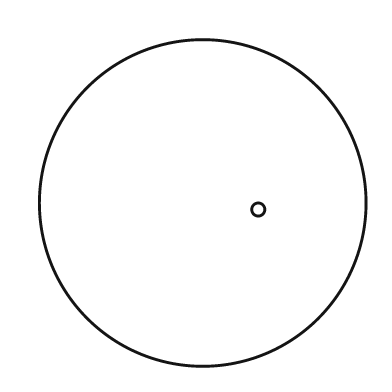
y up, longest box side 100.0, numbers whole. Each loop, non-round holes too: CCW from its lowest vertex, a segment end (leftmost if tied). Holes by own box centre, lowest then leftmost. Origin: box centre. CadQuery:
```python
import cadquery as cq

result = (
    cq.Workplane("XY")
    .moveTo(0.0, 0.0)
    .circle(50.0)
    .moveTo(17.0, -2.0)
    .circle(2.0)
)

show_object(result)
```